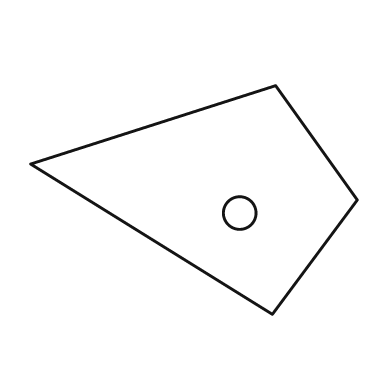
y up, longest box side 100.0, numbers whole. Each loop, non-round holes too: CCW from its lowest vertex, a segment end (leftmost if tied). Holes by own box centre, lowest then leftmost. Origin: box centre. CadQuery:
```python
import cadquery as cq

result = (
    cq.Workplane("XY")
    .moveTo(24.0, -35.0)
    .lineTo(50.0, 0.0)
    .lineTo(25.0, 35.0)
    .lineTo(-50.0, 11.0)
    .close()
    .moveTo(14.0, -4.0)
    .circle(5.0)
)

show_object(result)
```